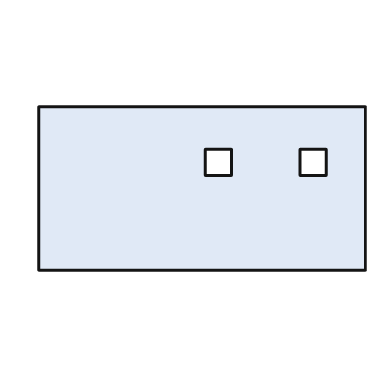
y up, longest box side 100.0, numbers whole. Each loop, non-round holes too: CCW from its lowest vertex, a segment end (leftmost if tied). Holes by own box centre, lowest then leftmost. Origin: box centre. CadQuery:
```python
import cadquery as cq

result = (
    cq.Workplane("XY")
    .moveTo(-50.0, -25.0)
    .lineTo(50.0, -25.0)
    .lineTo(50.0, 25.0)
    .lineTo(-50.0, 25.0)
    .close()
    .moveTo(1.0, 4.0)
    .lineTo(9.0, 4.0)
    .lineTo(9.0, 12.0)
    .lineTo(1.0, 12.0)
    .close()
    .moveTo(30.0, 4.0)
    .lineTo(38.0, 4.0)
    .lineTo(38.0, 12.0)
    .lineTo(30.0, 12.0)
    .close()
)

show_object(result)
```